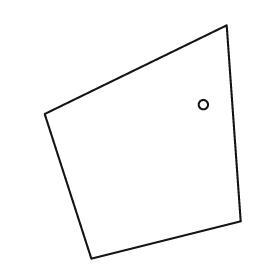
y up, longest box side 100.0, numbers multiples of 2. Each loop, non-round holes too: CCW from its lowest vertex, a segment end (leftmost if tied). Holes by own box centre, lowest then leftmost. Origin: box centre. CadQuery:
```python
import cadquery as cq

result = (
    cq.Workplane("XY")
    .moveTo(-22.0, -50.0)
    .lineTo(42.0, -34.0)
    .lineTo(36.0, 50.0)
    .lineTo(-42.0, 12.0)
    .close()
    .moveTo(26.0, 16.0)
    .circle(2.0)
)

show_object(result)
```